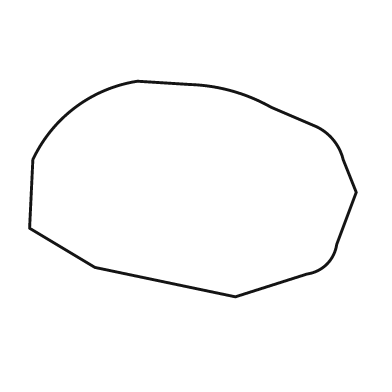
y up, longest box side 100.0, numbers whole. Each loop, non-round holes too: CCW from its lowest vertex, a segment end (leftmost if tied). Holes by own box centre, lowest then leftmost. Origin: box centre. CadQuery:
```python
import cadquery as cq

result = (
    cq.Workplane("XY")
    .moveTo(13.0, -33.0)
    .lineTo(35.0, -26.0)
    .threePointArc((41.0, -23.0), (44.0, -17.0))
    .lineTo(50.0, -1.0)
    .lineTo(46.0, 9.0)
    .threePointArc((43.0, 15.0), (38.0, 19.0))
    .lineTo(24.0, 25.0)
    .threePointArc((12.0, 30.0), (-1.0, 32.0))
    .lineTo(-17.0, 33.0)
    .threePointArc((-36.0, 25.0), (-49.0, 9.0))
    .lineTo(-50.0, -12.0)
    .lineTo(-30.0, -24.0)
    .close()
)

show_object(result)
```